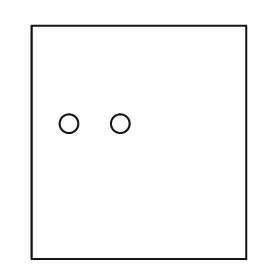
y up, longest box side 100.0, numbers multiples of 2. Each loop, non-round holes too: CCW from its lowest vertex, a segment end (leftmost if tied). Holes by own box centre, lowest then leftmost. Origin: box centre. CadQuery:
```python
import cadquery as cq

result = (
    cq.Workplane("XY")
    .moveTo(-46.0, -50.0)
    .lineTo(46.0, -50.0)
    .lineTo(46.0, 50.0)
    .lineTo(-46.0, 50.0)
    .close()
    .moveTo(-30.0, 8.0)
    .circle(4.0)
    .moveTo(-8.0, 8.0)
    .circle(4.0)
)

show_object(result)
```